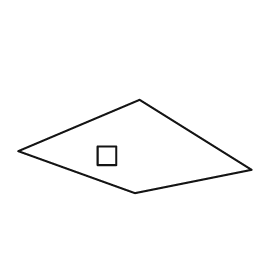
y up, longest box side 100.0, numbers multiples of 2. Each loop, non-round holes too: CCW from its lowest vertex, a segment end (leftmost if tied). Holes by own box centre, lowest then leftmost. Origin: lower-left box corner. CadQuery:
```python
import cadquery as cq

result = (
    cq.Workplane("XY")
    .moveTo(50.0, 0.0)
    .lineTo(100.0, 10.0)
    .lineTo(52.0, 40.0)
    .lineTo(0.0, 18.0)
    .close()
    .moveTo(34.0, 12.0)
    .lineTo(42.0, 12.0)
    .lineTo(42.0, 20.0)
    .lineTo(34.0, 20.0)
    .close()
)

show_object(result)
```